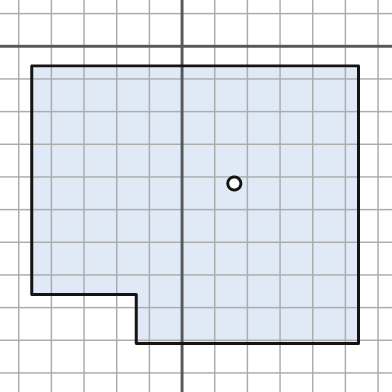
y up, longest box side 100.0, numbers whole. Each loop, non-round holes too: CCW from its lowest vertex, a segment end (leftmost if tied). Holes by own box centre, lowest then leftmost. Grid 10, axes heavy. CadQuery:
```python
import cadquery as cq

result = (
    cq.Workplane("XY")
    .moveTo(-14.0, -91.0)
    .lineTo(54.0, -91.0)
    .lineTo(54.0, -6.0)
    .lineTo(-46.0, -6.0)
    .lineTo(-46.0, -76.0)
    .lineTo(-14.0, -76.0)
    .close()
    .moveTo(16.0, -42.0)
    .circle(2.0)
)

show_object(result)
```